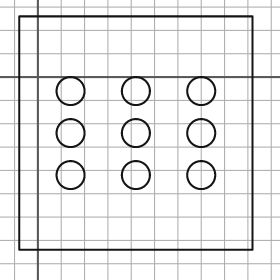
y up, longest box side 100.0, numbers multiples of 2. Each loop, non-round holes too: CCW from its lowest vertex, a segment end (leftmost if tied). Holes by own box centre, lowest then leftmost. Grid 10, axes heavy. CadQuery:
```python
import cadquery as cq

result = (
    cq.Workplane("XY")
    .moveTo(-8.0, -74.0)
    .lineTo(92.0, -74.0)
    .lineTo(92.0, 26.0)
    .lineTo(-8.0, 26.0)
    .close()
    .moveTo(14.0, -42.0)
    .circle(6.0)
    .moveTo(42.0, -42.0)
    .circle(6.0)
    .moveTo(70.0, -42.0)
    .circle(6.0)
    .moveTo(14.0, -24.0)
    .circle(6.0)
    .moveTo(42.0, -24.0)
    .circle(6.0)
    .moveTo(70.0, -24.0)
    .circle(6.0)
    .moveTo(14.0, -6.0)
    .circle(6.0)
    .moveTo(42.0, -6.0)
    .circle(6.0)
    .moveTo(70.0, -6.0)
    .circle(6.0)
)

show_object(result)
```